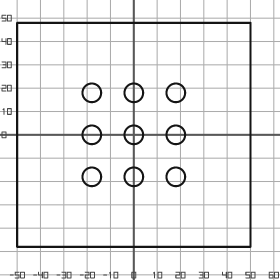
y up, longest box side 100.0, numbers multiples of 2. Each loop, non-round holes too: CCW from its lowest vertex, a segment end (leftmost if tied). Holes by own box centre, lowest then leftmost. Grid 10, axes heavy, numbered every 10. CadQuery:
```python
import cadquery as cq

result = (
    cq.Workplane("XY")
    .moveTo(-50.0, -48.0)
    .lineTo(50.0, -48.0)
    .lineTo(50.0, 48.0)
    .lineTo(-50.0, 48.0)
    .close()
    .moveTo(-18.0, -18.0)
    .circle(4.0)
    .moveTo(0.0, -18.0)
    .circle(4.0)
    .moveTo(18.0, -18.0)
    .circle(4.0)
    .moveTo(-18.0, 0.0)
    .circle(4.0)
    .moveTo(0.0, 0.0)
    .circle(4.0)
    .moveTo(18.0, 0.0)
    .circle(4.0)
    .moveTo(-18.0, 18.0)
    .circle(4.0)
    .moveTo(0.0, 18.0)
    .circle(4.0)
    .moveTo(18.0, 18.0)
    .circle(4.0)
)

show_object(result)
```